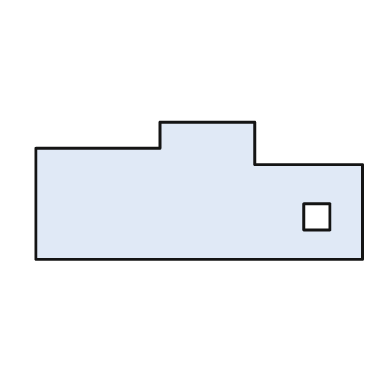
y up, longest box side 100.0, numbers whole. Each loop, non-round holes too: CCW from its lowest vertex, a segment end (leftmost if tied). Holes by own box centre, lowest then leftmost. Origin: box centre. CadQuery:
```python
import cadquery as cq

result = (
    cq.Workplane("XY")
    .moveTo(-50.0, -21.0)
    .lineTo(50.0, -21.0)
    .lineTo(50.0, 8.0)
    .lineTo(17.0, 8.0)
    .lineTo(17.0, 21.0)
    .lineTo(-12.0, 21.0)
    .lineTo(-12.0, 13.0)
    .lineTo(-50.0, 13.0)
    .close()
    .moveTo(32.0, -12.0)
    .lineTo(40.0, -12.0)
    .lineTo(40.0, -4.0)
    .lineTo(32.0, -4.0)
    .close()
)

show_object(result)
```